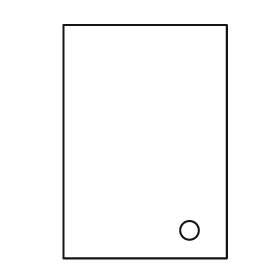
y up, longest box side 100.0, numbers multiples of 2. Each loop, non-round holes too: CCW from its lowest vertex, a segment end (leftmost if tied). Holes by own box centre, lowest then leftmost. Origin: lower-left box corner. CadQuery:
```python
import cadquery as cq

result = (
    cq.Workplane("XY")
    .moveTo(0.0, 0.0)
    .lineTo(70.0, 0.0)
    .lineTo(70.0, 100.0)
    .lineTo(0.0, 100.0)
    .close()
    .moveTo(54.0, 12.0)
    .circle(4.0)
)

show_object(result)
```